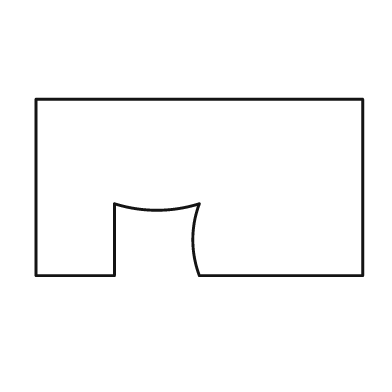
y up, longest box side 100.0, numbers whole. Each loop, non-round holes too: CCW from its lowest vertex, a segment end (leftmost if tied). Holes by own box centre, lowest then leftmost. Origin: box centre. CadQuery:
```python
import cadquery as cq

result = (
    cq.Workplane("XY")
    .moveTo(-50.0, -27.0)
    .lineTo(-26.0, -27.0)
    .lineTo(-26.0, -5.0)
    .threePointArc((-13.0, -7.0), (0.0, -5.0))
    .threePointArc((-2.0, -16.0), (0.0, -27.0))
    .lineTo(50.0, -27.0)
    .lineTo(50.0, 27.0)
    .lineTo(-50.0, 27.0)
    .close()
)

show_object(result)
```